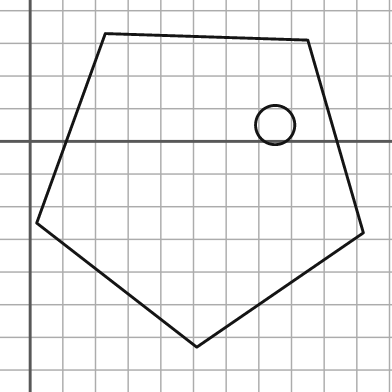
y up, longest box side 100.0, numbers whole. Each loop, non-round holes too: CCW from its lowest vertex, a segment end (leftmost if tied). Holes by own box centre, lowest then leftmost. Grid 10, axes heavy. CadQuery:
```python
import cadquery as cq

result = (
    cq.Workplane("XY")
    .moveTo(51.0, -63.0)
    .lineTo(102.0, -28.0)
    .lineTo(85.0, 31.0)
    .lineTo(23.0, 33.0)
    .lineTo(2.0, -25.0)
    .close()
    .moveTo(75.0, 5.0)
    .circle(6.0)
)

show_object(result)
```